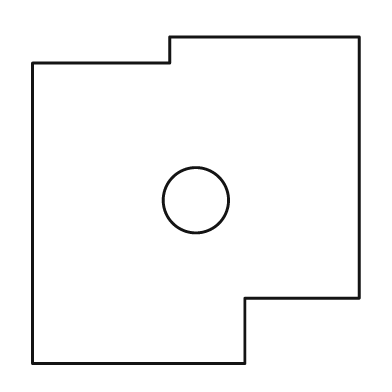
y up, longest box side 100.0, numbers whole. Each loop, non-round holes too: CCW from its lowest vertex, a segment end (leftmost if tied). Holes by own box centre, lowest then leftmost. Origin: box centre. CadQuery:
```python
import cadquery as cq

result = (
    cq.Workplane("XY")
    .moveTo(-50.0, -50.0)
    .lineTo(15.0, -50.0)
    .lineTo(15.0, -30.0)
    .lineTo(50.0, -30.0)
    .lineTo(50.0, 50.0)
    .lineTo(-8.0, 50.0)
    .lineTo(-8.0, 42.0)
    .lineTo(-50.0, 42.0)
    .close()
    .moveTo(0.0, 0.0)
    .circle(10.0)
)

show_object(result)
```